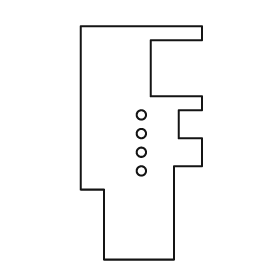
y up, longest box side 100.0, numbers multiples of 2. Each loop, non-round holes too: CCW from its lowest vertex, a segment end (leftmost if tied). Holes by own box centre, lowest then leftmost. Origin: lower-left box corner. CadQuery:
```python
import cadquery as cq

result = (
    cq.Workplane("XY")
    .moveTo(10.0, 0.0)
    .lineTo(40.0, 0.0)
    .lineTo(40.0, 40.0)
    .lineTo(52.0, 40.0)
    .lineTo(52.0, 52.0)
    .lineTo(42.0, 52.0)
    .lineTo(42.0, 64.0)
    .lineTo(52.0, 64.0)
    .lineTo(52.0, 70.0)
    .lineTo(30.0, 70.0)
    .lineTo(30.0, 94.0)
    .lineTo(52.0, 94.0)
    .lineTo(52.0, 100.0)
    .lineTo(0.0, 100.0)
    .lineTo(0.0, 30.0)
    .lineTo(10.0, 30.0)
    .close()
    .moveTo(26.0, 38.0)
    .circle(2.0)
    .moveTo(26.0, 46.0)
    .circle(2.0)
    .moveTo(26.0, 54.0)
    .circle(2.0)
    .moveTo(26.0, 62.0)
    .circle(2.0)
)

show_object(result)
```